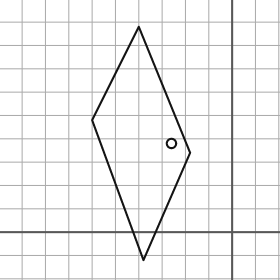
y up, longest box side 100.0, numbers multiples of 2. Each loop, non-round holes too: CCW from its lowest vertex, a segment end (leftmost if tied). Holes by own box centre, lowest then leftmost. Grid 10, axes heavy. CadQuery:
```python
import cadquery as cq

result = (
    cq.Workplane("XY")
    .moveTo(-38.0, -12.0)
    .lineTo(-18.0, 34.0)
    .lineTo(-40.0, 88.0)
    .lineTo(-60.0, 48.0)
    .close()
    .moveTo(-26.0, 38.0)
    .circle(2.0)
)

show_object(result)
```